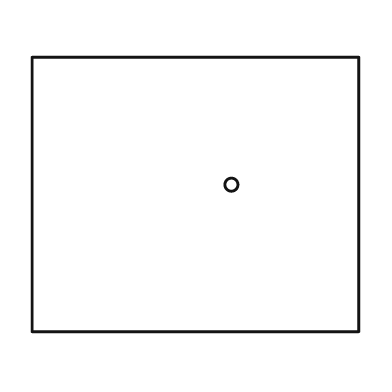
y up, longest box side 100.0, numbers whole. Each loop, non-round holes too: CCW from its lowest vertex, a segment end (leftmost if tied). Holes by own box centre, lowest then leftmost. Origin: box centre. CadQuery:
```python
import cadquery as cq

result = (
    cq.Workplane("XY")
    .moveTo(-50.0, -42.0)
    .lineTo(50.0, -42.0)
    .lineTo(50.0, 42.0)
    .lineTo(-50.0, 42.0)
    .close()
    .moveTo(11.0, 3.0)
    .circle(2.0)
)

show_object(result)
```